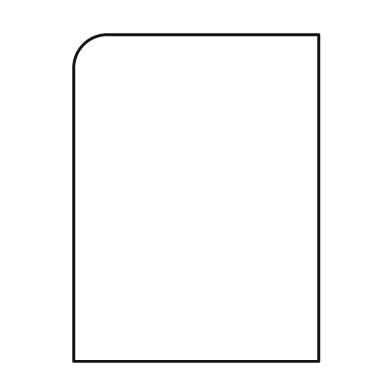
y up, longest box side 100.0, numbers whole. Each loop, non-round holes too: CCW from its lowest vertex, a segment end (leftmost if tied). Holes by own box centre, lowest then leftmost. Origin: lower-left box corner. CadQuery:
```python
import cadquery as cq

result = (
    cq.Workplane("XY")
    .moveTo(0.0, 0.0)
    .lineTo(75.0, 0.0)
    .lineTo(75.0, 100.0)
    .lineTo(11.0, 100.0)
    .threePointArc((3.0, 97.0), (0.0, 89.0))
    .close()
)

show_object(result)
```